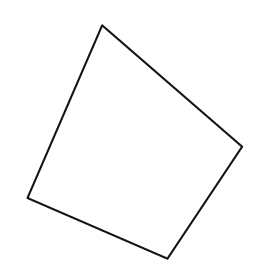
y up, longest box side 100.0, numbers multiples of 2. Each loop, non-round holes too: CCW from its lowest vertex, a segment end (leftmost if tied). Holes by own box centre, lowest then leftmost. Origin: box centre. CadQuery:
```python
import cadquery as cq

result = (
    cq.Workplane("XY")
    .moveTo(14.0, -50.0)
    .lineTo(46.0, -2.0)
    .lineTo(-14.0, 50.0)
    .lineTo(-46.0, -24.0)
    .close()
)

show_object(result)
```